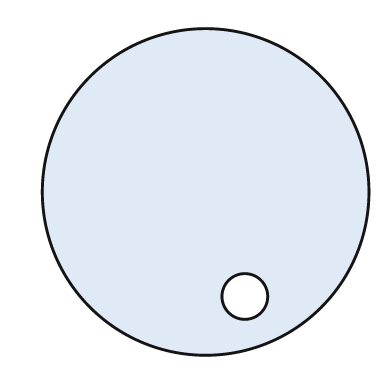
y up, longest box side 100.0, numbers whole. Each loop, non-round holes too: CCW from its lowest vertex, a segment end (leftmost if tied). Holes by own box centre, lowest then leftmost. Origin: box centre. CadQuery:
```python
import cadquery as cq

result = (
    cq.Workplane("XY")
    .moveTo(0.0, 0.0)
    .circle(50.0)
    .moveTo(12.0, -32.0)
    .circle(7.0)
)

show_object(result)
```